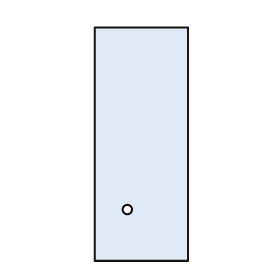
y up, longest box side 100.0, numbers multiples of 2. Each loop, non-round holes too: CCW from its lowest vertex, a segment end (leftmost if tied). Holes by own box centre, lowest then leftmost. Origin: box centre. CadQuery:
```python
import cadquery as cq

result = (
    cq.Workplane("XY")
    .moveTo(-20.0, -50.0)
    .lineTo(20.0, -50.0)
    .lineTo(20.0, 50.0)
    .lineTo(-20.0, 50.0)
    .close()
    .moveTo(-6.0, -28.0)
    .circle(2.0)
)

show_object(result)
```